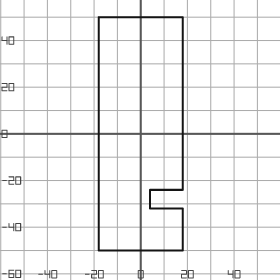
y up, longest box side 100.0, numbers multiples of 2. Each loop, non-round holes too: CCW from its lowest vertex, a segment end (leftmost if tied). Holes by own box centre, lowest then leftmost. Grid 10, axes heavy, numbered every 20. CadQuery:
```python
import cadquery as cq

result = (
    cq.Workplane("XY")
    .moveTo(-18.0, -50.0)
    .lineTo(18.0, -50.0)
    .lineTo(18.0, -32.0)
    .lineTo(4.0, -32.0)
    .lineTo(4.0, -24.0)
    .lineTo(18.0, -24.0)
    .lineTo(18.0, 50.0)
    .lineTo(-18.0, 50.0)
    .close()
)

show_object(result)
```